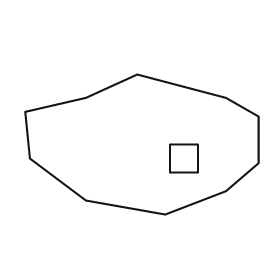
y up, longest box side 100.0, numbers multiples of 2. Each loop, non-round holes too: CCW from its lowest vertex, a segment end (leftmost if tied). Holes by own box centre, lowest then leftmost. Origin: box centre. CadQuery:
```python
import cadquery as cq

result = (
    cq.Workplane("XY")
    .moveTo(10.0, -30.0)
    .lineTo(36.0, -20.0)
    .lineTo(50.0, -8.0)
    .lineTo(50.0, 12.0)
    .lineTo(36.0, 20.0)
    .lineTo(-2.0, 30.0)
    .lineTo(-24.0, 20.0)
    .lineTo(-50.0, 14.0)
    .lineTo(-48.0, -6.0)
    .lineTo(-24.0, -24.0)
    .close()
    .moveTo(12.0, -12.0)
    .lineTo(24.0, -12.0)
    .lineTo(24.0, 0.0)
    .lineTo(12.0, 0.0)
    .close()
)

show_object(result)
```